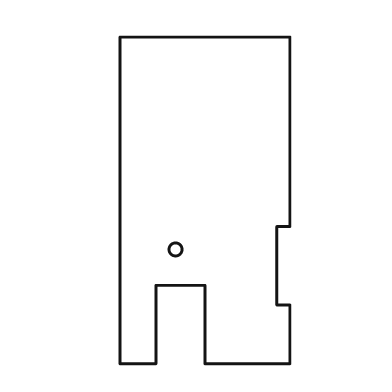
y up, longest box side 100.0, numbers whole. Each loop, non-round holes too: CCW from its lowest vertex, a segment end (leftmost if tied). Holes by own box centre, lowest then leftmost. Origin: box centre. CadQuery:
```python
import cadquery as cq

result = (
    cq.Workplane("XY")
    .moveTo(-26.0, -50.0)
    .lineTo(-15.0, -50.0)
    .lineTo(-15.0, -26.0)
    .lineTo(0.0, -26.0)
    .lineTo(0.0, -50.0)
    .lineTo(26.0, -50.0)
    .lineTo(26.0, -32.0)
    .lineTo(22.0, -32.0)
    .lineTo(22.0, -8.0)
    .lineTo(26.0, -8.0)
    .lineTo(26.0, 50.0)
    .lineTo(-26.0, 50.0)
    .close()
    .moveTo(-9.0, -15.0)
    .circle(2.0)
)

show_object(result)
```